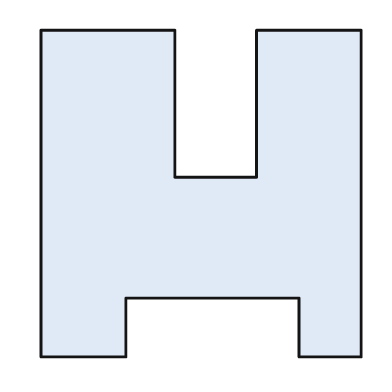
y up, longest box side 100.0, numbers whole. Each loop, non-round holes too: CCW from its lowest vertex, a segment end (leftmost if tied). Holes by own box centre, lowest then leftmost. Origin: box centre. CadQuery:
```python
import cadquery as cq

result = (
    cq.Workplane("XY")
    .moveTo(-49.0, -50.0)
    .lineTo(-23.0, -50.0)
    .lineTo(-23.0, -32.0)
    .lineTo(30.0, -32.0)
    .lineTo(30.0, -50.0)
    .lineTo(49.0, -50.0)
    .lineTo(49.0, 50.0)
    .lineTo(17.0, 50.0)
    .lineTo(17.0, 5.0)
    .lineTo(-8.0, 5.0)
    .lineTo(-8.0, 50.0)
    .lineTo(-49.0, 50.0)
    .close()
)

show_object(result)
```